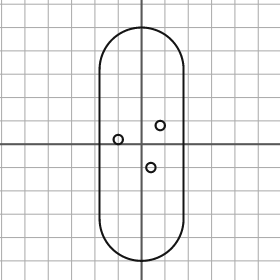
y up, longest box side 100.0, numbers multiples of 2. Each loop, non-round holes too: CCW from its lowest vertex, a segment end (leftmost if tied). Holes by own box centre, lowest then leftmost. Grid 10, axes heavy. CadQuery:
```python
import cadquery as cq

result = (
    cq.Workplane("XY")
    .moveTo(-18.0, -32.0)
    .threePointArc((0.0, -50.0), (18.0, -32.0))
    .lineTo(18.0, 32.0)
    .threePointArc((0.0, 50.0), (-18.0, 32.0))
    .close()
    .moveTo(4.0, -10.0)
    .circle(2.0)
    .moveTo(-10.0, 2.0)
    .circle(2.0)
    .moveTo(8.0, 8.0)
    .circle(2.0)
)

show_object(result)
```